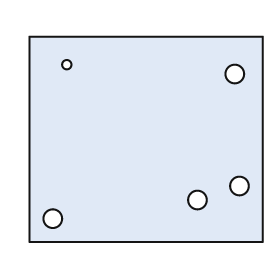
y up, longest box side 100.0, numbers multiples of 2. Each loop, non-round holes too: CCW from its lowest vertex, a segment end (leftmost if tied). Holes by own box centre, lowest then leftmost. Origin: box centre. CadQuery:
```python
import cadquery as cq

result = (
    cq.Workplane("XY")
    .moveTo(-50.0, -44.0)
    .lineTo(50.0, -44.0)
    .lineTo(50.0, 44.0)
    .lineTo(-50.0, 44.0)
    .close()
    .moveTo(-40.0, -34.0)
    .circle(4.0)
    .moveTo(22.0, -26.0)
    .circle(4.0)
    .moveTo(40.0, -20.0)
    .circle(4.0)
    .moveTo(38.0, 28.0)
    .circle(4.0)
    .moveTo(-34.0, 32.0)
    .circle(2.0)
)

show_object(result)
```